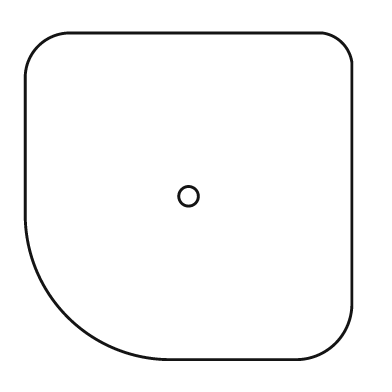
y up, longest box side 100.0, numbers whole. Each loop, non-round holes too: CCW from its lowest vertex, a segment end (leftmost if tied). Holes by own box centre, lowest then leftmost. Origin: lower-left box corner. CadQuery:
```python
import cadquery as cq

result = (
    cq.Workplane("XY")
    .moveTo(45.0, 0.0)
    .lineTo(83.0, 0.0)
    .threePointArc((95.0, 5.0), (100.0, 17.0))
    .lineTo(100.0, 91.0)
    .threePointArc((97.0, 97.0), (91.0, 100.0))
    .lineTo(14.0, 100.0)
    .threePointArc((4.0, 96.0), (0.0, 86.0))
    .lineTo(0.0, 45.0)
    .threePointArc((13.0, 13.0), (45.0, 0.0))
    .close()
    .moveTo(50.0, 50.0)
    .circle(3.0)
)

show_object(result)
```